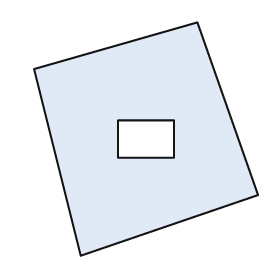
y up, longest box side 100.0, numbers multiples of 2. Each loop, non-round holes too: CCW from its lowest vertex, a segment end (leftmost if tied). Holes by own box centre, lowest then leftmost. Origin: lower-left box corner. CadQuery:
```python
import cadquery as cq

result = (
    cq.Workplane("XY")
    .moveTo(20.0, 0.0)
    .lineTo(96.0, 26.0)
    .lineTo(70.0, 100.0)
    .lineTo(0.0, 80.0)
    .close()
    .moveTo(36.0, 42.0)
    .lineTo(60.0, 42.0)
    .lineTo(60.0, 58.0)
    .lineTo(36.0, 58.0)
    .close()
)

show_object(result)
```